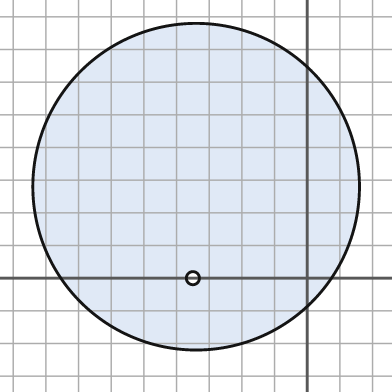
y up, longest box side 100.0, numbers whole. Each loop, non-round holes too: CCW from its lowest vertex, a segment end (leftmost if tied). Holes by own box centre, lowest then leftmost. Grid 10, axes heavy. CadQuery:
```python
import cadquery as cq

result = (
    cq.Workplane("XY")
    .moveTo(-34.0, 28.0)
    .circle(50.0)
    .moveTo(-35.0, 0.0)
    .circle(2.0)
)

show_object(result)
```